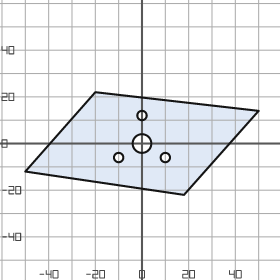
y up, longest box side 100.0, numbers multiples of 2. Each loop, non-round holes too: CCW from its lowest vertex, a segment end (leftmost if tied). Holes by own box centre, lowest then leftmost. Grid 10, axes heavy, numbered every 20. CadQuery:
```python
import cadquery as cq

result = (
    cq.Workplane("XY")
    .moveTo(18.0, -22.0)
    .lineTo(50.0, 14.0)
    .lineTo(-20.0, 22.0)
    .lineTo(-50.0, -12.0)
    .close()
    .moveTo(-10.0, -6.0)
    .circle(2.0)
    .moveTo(10.0, -6.0)
    .circle(2.0)
    .moveTo(0.0, 0.0)
    .circle(4.0)
    .moveTo(0.0, 12.0)
    .circle(2.0)
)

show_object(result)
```